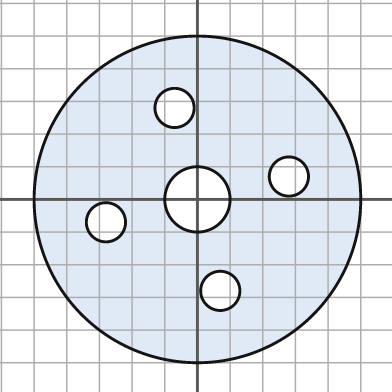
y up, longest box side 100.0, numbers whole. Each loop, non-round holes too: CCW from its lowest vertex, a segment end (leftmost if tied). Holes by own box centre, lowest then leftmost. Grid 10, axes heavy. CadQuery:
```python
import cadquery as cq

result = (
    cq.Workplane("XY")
    .moveTo(0.0, 0.0)
    .circle(50.0)
    .moveTo(7.0, -28.0)
    .circle(6.0)
    .moveTo(-28.0, -7.0)
    .circle(6.0)
    .moveTo(0.0, 0.0)
    .circle(10.0)
    .moveTo(28.0, 7.0)
    .circle(6.0)
    .moveTo(-7.0, 28.0)
    .circle(6.0)
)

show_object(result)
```